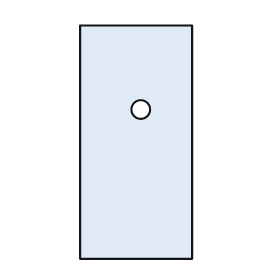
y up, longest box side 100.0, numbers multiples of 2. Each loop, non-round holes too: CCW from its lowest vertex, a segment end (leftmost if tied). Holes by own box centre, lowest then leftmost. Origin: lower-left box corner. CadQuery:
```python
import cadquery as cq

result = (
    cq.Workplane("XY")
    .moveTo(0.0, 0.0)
    .lineTo(48.0, 0.0)
    .lineTo(48.0, 100.0)
    .lineTo(0.0, 100.0)
    .close()
    .moveTo(26.0, 64.0)
    .circle(4.0)
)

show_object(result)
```